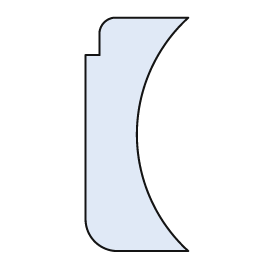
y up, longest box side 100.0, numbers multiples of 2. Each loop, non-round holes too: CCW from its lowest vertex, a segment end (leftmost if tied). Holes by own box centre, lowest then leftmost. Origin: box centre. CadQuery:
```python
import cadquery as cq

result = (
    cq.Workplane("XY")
    .moveTo(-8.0, -50.0)
    .lineTo(22.0, -50.0)
    .threePointArc((0.0, 0.0), (22.0, 50.0))
    .lineTo(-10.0, 50.0)
    .threePointArc((-14.0, 48.0), (-16.0, 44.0))
    .lineTo(-16.0, 34.0)
    .lineTo(-22.0, 34.0)
    .lineTo(-22.0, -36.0)
    .threePointArc((-18.0, -46.0), (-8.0, -50.0))
    .close()
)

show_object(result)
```